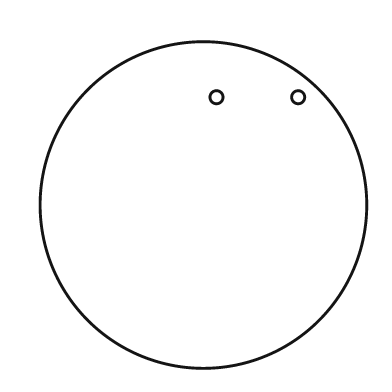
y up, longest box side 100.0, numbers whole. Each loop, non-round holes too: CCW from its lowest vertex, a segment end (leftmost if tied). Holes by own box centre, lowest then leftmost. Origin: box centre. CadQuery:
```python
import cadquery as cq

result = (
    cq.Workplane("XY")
    .moveTo(0.0, 0.0)
    .circle(50.0)
    .moveTo(4.0, 33.0)
    .circle(2.0)
    .moveTo(29.0, 33.0)
    .circle(2.0)
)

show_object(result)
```